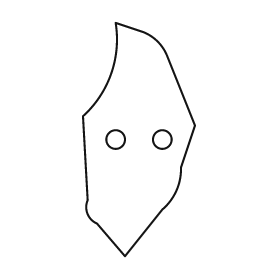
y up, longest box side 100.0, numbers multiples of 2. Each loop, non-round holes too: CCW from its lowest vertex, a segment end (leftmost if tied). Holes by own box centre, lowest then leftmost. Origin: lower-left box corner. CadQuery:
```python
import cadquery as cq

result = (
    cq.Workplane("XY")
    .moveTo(18.0, 0.0)
    .lineTo(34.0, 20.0)
    .threePointArc((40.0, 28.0), (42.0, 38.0))
    .lineTo(48.0, 56.0)
    .lineTo(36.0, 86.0)
    .threePointArc((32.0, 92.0), (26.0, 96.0))
    .lineTo(14.0, 100.0)
    .threePointArc((12.0, 78.0), (0.0, 60.0))
    .lineTo(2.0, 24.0)
    .threePointArc((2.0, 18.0), (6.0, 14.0))
    .close()
    .moveTo(14.0, 50.0)
    .circle(4.0)
    .moveTo(34.0, 50.0)
    .circle(4.0)
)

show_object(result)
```